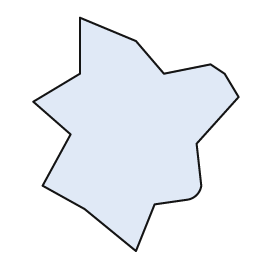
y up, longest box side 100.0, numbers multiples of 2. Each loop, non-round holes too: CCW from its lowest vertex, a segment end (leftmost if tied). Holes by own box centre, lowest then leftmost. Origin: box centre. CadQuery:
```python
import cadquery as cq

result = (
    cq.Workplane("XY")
    .moveTo(0.0, -50.0)
    .lineTo(8.0, -30.0)
    .lineTo(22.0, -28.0)
    .threePointArc((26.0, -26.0), (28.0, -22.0))
    .lineTo(26.0, -4.0)
    .lineTo(44.0, 16.0)
    .lineTo(38.0, 26.0)
    .lineTo(32.0, 30.0)
    .lineTo(12.0, 26.0)
    .lineTo(0.0, 40.0)
    .lineTo(-24.0, 50.0)
    .lineTo(-24.0, 26.0)
    .lineTo(-44.0, 14.0)
    .lineTo(-28.0, 0.0)
    .lineTo(-40.0, -22.0)
    .lineTo(-22.0, -32.0)
    .close()
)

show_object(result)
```